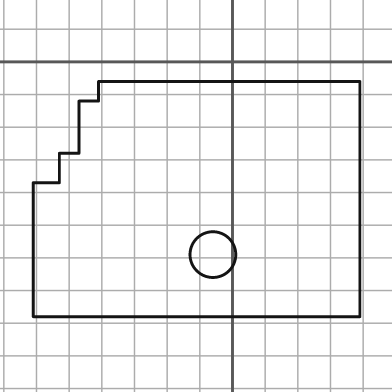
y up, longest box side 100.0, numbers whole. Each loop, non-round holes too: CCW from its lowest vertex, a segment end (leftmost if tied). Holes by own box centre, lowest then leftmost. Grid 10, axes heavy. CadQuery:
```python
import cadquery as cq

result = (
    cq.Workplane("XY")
    .moveTo(-61.0, -78.0)
    .lineTo(39.0, -78.0)
    .lineTo(39.0, -6.0)
    .lineTo(-41.0, -6.0)
    .lineTo(-41.0, -12.0)
    .lineTo(-47.0, -12.0)
    .lineTo(-47.0, -28.0)
    .lineTo(-53.0, -28.0)
    .lineTo(-53.0, -37.0)
    .lineTo(-61.0, -37.0)
    .close()
    .moveTo(-6.0, -59.0)
    .circle(7.0)
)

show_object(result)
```